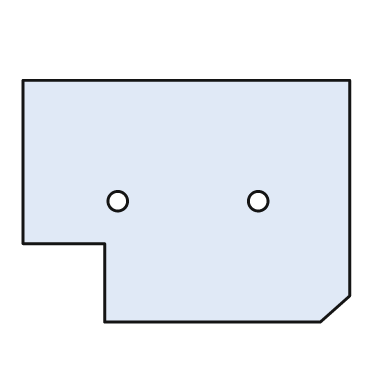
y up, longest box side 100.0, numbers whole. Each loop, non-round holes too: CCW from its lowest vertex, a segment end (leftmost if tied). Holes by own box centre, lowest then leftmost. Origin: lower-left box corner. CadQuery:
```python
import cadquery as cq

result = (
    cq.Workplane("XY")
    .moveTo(25.0, 0.0)
    .lineTo(91.0, 0.0)
    .lineTo(100.0, 8.0)
    .lineTo(100.0, 74.0)
    .lineTo(0.0, 74.0)
    .lineTo(0.0, 24.0)
    .lineTo(25.0, 24.0)
    .close()
    .moveTo(29.0, 37.0)
    .circle(3.0)
    .moveTo(72.0, 37.0)
    .circle(3.0)
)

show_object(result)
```